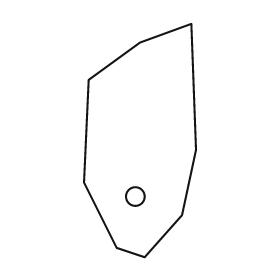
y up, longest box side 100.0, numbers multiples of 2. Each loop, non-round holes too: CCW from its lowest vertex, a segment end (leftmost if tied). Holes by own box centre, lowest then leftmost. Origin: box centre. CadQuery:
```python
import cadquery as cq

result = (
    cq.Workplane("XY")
    .moveTo(2.0, -50.0)
    .lineTo(18.0, -32.0)
    .lineTo(24.0, -4.0)
    .lineTo(22.0, 50.0)
    .lineTo(0.0, 42.0)
    .lineTo(-22.0, 26.0)
    .lineTo(-24.0, -18.0)
    .lineTo(-10.0, -46.0)
    .close()
    .moveTo(-2.0, -24.0)
    .circle(4.0)
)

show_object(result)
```